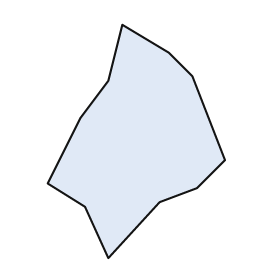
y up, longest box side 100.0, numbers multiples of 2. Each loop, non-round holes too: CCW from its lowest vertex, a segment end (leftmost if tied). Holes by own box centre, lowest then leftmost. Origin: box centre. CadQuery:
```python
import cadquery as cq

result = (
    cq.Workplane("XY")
    .moveTo(-12.0, -50.0)
    .lineTo(10.0, -26.0)
    .lineTo(26.0, -20.0)
    .lineTo(38.0, -8.0)
    .lineTo(24.0, 28.0)
    .lineTo(14.0, 38.0)
    .lineTo(-6.0, 50.0)
    .lineTo(-12.0, 26.0)
    .lineTo(-24.0, 10.0)
    .lineTo(-38.0, -18.0)
    .lineTo(-22.0, -28.0)
    .close()
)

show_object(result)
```